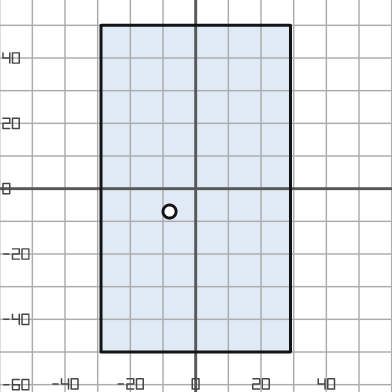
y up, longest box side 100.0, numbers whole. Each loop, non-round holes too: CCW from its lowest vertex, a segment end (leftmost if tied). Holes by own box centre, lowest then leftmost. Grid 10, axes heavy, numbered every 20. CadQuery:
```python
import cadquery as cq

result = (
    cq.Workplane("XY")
    .moveTo(-29.0, -50.0)
    .lineTo(29.0, -50.0)
    .lineTo(29.0, 50.0)
    .lineTo(-29.0, 50.0)
    .close()
    .moveTo(-8.0, -7.0)
    .circle(2.0)
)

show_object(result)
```